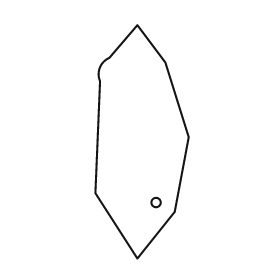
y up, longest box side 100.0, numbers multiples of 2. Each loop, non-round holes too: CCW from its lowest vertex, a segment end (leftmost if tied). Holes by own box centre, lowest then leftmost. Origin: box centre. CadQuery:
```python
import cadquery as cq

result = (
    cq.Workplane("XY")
    .moveTo(-2.0, -50.0)
    .lineTo(14.0, -30.0)
    .lineTo(20.0, 2.0)
    .lineTo(10.0, 34.0)
    .lineTo(-2.0, 50.0)
    .lineTo(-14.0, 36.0)
    .threePointArc((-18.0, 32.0), (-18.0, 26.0))
    .lineTo(-20.0, -22.0)
    .close()
    .moveTo(6.0, -26.0)
    .circle(2.0)
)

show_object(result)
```